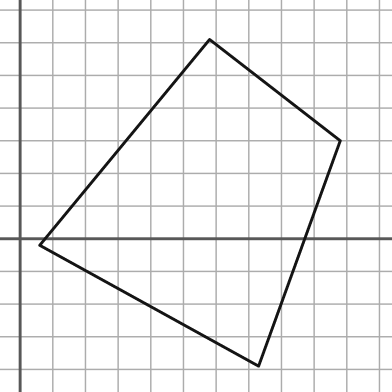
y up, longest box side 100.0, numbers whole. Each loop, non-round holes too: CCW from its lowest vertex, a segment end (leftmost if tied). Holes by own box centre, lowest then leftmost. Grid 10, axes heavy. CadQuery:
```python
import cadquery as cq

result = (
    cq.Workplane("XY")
    .moveTo(73.0, -39.0)
    .lineTo(98.0, 30.0)
    .lineTo(58.0, 61.0)
    .lineTo(6.0, -2.0)
    .close()
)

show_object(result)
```